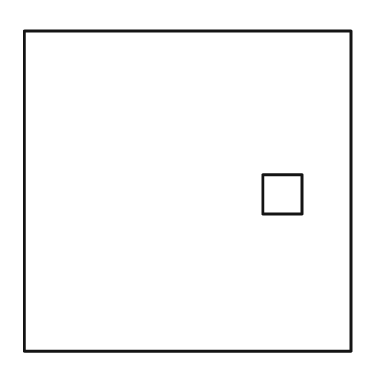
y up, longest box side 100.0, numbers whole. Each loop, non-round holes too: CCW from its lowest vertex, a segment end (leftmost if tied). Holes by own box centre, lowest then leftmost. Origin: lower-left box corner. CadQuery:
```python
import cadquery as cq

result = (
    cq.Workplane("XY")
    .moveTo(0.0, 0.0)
    .lineTo(100.0, 0.0)
    .lineTo(100.0, 98.0)
    .lineTo(0.0, 98.0)
    .close()
    .moveTo(73.0, 42.0)
    .lineTo(85.0, 42.0)
    .lineTo(85.0, 54.0)
    .lineTo(73.0, 54.0)
    .close()
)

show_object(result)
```